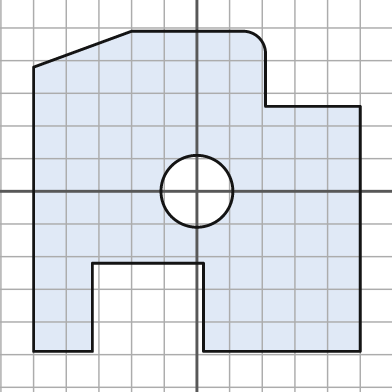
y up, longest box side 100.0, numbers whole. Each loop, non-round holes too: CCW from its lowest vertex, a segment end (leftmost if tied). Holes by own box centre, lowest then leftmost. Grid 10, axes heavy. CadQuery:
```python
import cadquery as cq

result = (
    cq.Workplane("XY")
    .moveTo(-50.0, -49.0)
    .lineTo(-32.0, -49.0)
    .lineTo(-32.0, -22.0)
    .lineTo(2.0, -22.0)
    .lineTo(2.0, -49.0)
    .lineTo(50.0, -49.0)
    .lineTo(50.0, 26.0)
    .lineTo(21.0, 26.0)
    .lineTo(21.0, 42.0)
    .threePointArc((19.0, 47.0), (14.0, 49.0))
    .lineTo(-20.0, 49.0)
    .lineTo(-50.0, 38.0)
    .close()
    .moveTo(0.0, 0.0)
    .circle(11.0)
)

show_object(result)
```